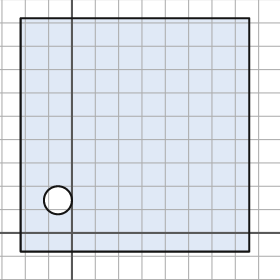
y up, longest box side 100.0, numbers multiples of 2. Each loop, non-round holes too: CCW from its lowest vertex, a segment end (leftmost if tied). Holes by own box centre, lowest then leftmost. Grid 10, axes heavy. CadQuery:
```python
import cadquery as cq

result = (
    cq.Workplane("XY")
    .moveTo(-22.0, -8.0)
    .lineTo(76.0, -8.0)
    .lineTo(76.0, 92.0)
    .lineTo(-22.0, 92.0)
    .close()
    .moveTo(-6.0, 14.0)
    .circle(6.0)
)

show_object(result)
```